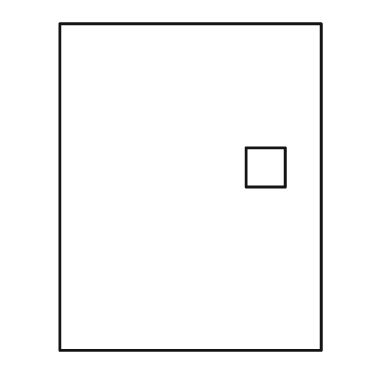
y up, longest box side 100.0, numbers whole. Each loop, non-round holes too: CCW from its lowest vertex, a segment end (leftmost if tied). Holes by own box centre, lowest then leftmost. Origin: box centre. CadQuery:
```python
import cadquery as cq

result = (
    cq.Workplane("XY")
    .moveTo(-40.0, -50.0)
    .lineTo(40.0, -50.0)
    .lineTo(40.0, 50.0)
    .lineTo(-40.0, 50.0)
    .close()
    .moveTo(17.0, 0.0)
    .lineTo(29.0, 0.0)
    .lineTo(29.0, 12.0)
    .lineTo(17.0, 12.0)
    .close()
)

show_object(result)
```